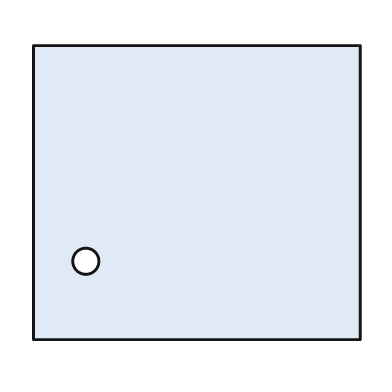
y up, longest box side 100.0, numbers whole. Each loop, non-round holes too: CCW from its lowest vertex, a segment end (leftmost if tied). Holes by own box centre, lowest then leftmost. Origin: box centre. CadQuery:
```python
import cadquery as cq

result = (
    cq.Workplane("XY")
    .moveTo(-50.0, -45.0)
    .lineTo(50.0, -45.0)
    .lineTo(50.0, 45.0)
    .lineTo(-50.0, 45.0)
    .close()
    .moveTo(-34.0, -21.0)
    .circle(4.0)
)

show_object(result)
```